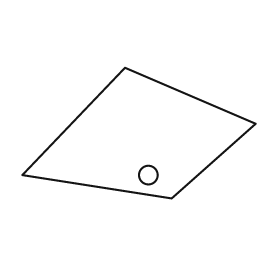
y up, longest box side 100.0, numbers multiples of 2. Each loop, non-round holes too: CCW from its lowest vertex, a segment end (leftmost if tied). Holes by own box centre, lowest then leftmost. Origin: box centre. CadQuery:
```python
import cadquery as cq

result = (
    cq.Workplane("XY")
    .moveTo(14.0, -28.0)
    .lineTo(50.0, 4.0)
    .lineTo(-6.0, 28.0)
    .lineTo(-50.0, -18.0)
    .close()
    .moveTo(4.0, -18.0)
    .circle(4.0)
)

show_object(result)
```